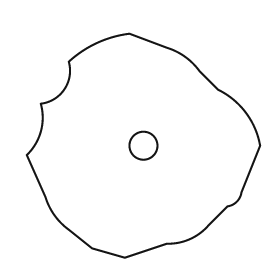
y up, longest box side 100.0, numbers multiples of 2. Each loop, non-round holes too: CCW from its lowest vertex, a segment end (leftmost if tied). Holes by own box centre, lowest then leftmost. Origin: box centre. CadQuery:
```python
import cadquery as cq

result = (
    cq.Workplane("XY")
    .moveTo(-8.0, -48.0)
    .lineTo(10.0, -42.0)
    .threePointArc((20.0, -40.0), (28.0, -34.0))
    .lineTo(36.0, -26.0)
    .threePointArc((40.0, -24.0), (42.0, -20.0))
    .lineTo(50.0, 0.0)
    .threePointArc((44.0, 14.0), (32.0, 24.0))
    .lineTo(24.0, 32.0)
    .threePointArc((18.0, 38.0), (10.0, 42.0))
    .lineTo(-6.0, 48.0)
    .threePointArc((-20.0, 44.0), (-32.0, 36.0))
    .threePointArc((-34.0, 24.0), (-44.0, 18.0))
    .threePointArc((-44.0, 6.0), (-50.0, -4.0))
    .lineTo(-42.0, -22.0)
    .threePointArc((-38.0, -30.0), (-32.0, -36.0))
    .lineTo(-22.0, -44.0)
    .close()
    .moveTo(0.0, 0.0)
    .circle(6.0)
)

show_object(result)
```